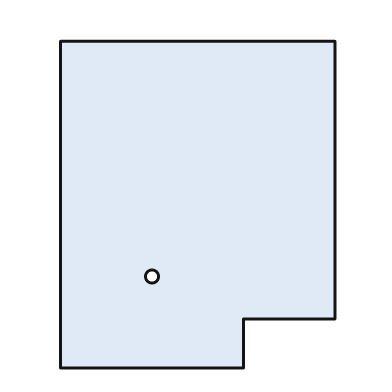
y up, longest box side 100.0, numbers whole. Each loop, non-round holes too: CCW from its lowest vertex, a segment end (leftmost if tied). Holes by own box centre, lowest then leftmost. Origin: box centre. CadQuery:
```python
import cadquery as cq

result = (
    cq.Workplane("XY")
    .moveTo(-42.0, -50.0)
    .lineTo(14.0, -50.0)
    .lineTo(14.0, -35.0)
    .lineTo(42.0, -35.0)
    .lineTo(42.0, 50.0)
    .lineTo(-42.0, 50.0)
    .close()
    .moveTo(-14.0, -22.0)
    .circle(2.0)
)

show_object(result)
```